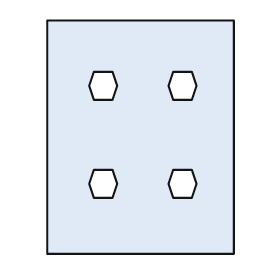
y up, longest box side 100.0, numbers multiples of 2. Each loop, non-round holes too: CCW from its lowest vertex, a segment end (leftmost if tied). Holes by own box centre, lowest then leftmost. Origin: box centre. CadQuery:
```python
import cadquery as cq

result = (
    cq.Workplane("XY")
    .moveTo(-40.0, -50.0)
    .lineTo(40.0, -50.0)
    .lineTo(40.0, 50.0)
    .lineTo(-40.0, 50.0)
    .close()
    .moveTo(-20.0, -26.0)
    .lineTo(-12.0, -26.0)
    .lineTo(-10.0, -20.0)
    .lineTo(-12.0, -14.0)
    .lineTo(-20.0, -14.0)
    .lineTo(-22.0, -20.0)
    .close()
    .moveTo(14.0, -26.0)
    .lineTo(22.0, -26.0)
    .lineTo(24.0, -20.0)
    .lineTo(22.0, -14.0)
    .lineTo(14.0, -14.0)
    .lineTo(12.0, -20.0)
    .close()
    .moveTo(-20.0, 16.0)
    .lineTo(-12.0, 16.0)
    .lineTo(-10.0, 22.0)
    .lineTo(-12.0, 28.0)
    .lineTo(-20.0, 28.0)
    .lineTo(-22.0, 22.0)
    .close()
    .moveTo(14.0, 16.0)
    .lineTo(22.0, 16.0)
    .lineTo(24.0, 22.0)
    .lineTo(22.0, 28.0)
    .lineTo(14.0, 28.0)
    .lineTo(12.0, 22.0)
    .close()
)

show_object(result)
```